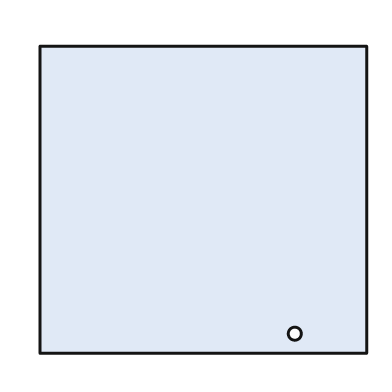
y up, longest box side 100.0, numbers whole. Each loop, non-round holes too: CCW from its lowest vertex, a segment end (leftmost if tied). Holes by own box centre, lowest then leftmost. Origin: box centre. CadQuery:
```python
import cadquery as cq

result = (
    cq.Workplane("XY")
    .moveTo(-50.0, -47.0)
    .lineTo(50.0, -47.0)
    .lineTo(50.0, 47.0)
    .lineTo(-50.0, 47.0)
    .close()
    .moveTo(28.0, -41.0)
    .circle(2.0)
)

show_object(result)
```